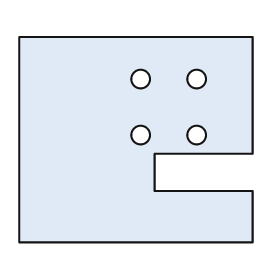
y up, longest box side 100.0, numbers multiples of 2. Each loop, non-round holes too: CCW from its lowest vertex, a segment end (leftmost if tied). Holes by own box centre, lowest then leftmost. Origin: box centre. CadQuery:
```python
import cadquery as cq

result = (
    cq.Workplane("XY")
    .moveTo(-50.0, -44.0)
    .lineTo(50.0, -44.0)
    .lineTo(50.0, -22.0)
    .lineTo(8.0, -22.0)
    .lineTo(8.0, -6.0)
    .lineTo(50.0, -6.0)
    .lineTo(50.0, 44.0)
    .lineTo(-50.0, 44.0)
    .close()
    .moveTo(2.0, 2.0)
    .circle(4.0)
    .moveTo(26.0, 2.0)
    .circle(4.0)
    .moveTo(2.0, 26.0)
    .circle(4.0)
    .moveTo(26.0, 26.0)
    .circle(4.0)
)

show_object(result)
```